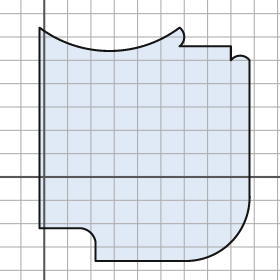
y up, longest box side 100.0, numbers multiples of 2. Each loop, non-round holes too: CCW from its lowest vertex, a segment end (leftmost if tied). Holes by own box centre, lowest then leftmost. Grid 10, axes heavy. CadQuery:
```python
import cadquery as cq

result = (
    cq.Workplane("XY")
    .moveTo(22.0, -36.0)
    .lineTo(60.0, -36.0)
    .threePointArc((80.0, -28.0), (88.0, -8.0))
    .lineTo(88.0, 50.0)
    .threePointArc((84.0, 52.0), (80.0, 50.0))
    .lineTo(80.0, 56.0)
    .lineTo(58.0, 56.0)
    .threePointArc((60.0, 60.0), (58.0, 64.0))
    .threePointArc((28.0, 54.0), (-2.0, 64.0))
    .lineTo(-2.0, -22.0)
    .lineTo(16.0, -22.0)
    .threePointArc((20.0, -24.0), (22.0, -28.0))
    .close()
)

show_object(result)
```